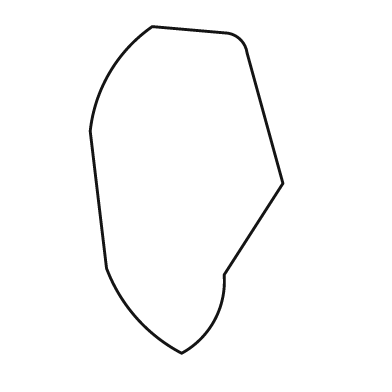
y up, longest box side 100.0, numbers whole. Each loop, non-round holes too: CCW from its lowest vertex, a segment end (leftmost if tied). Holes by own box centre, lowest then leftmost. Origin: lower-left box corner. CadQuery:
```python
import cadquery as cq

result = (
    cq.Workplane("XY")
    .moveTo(28.0, 0.0)
    .threePointArc((38.0, 10.0), (41.0, 24.0))
    .lineTo(59.0, 52.0)
    .lineTo(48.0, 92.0)
    .threePointArc((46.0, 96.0), (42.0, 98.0))
    .lineTo(19.0, 100.0)
    .threePointArc((6.0, 86.0), (0.0, 68.0))
    .lineTo(5.0, 26.0)
    .threePointArc((14.0, 11.0), (28.0, 0.0))
    .close()
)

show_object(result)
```